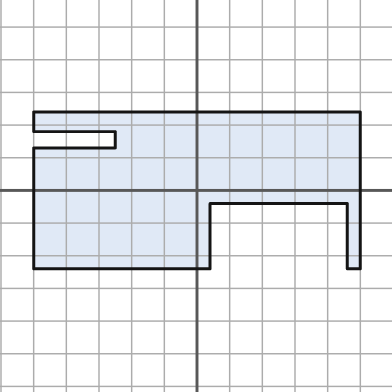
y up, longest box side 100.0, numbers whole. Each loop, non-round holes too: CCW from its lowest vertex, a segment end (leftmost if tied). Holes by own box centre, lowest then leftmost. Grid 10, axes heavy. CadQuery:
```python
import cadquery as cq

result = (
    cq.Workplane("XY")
    .moveTo(-50.0, -24.0)
    .lineTo(4.0, -24.0)
    .lineTo(4.0, -4.0)
    .lineTo(46.0, -4.0)
    .lineTo(46.0, -24.0)
    .lineTo(50.0, -24.0)
    .lineTo(50.0, 24.0)
    .lineTo(-50.0, 24.0)
    .lineTo(-50.0, 18.0)
    .lineTo(-25.0, 18.0)
    .lineTo(-25.0, 13.0)
    .lineTo(-50.0, 13.0)
    .close()
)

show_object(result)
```